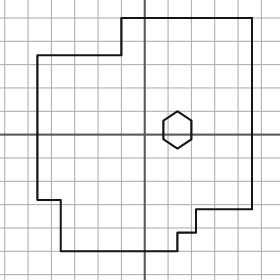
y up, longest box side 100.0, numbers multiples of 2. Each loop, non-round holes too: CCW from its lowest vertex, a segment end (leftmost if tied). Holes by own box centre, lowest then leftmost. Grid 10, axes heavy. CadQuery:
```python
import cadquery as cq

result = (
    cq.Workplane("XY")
    .moveTo(-36.0, -50.0)
    .lineTo(14.0, -50.0)
    .lineTo(14.0, -42.0)
    .lineTo(22.0, -42.0)
    .lineTo(22.0, -32.0)
    .lineTo(46.0, -32.0)
    .lineTo(46.0, 50.0)
    .lineTo(-10.0, 50.0)
    .lineTo(-10.0, 34.0)
    .lineTo(-46.0, 34.0)
    .lineTo(-46.0, -28.0)
    .lineTo(-36.0, -28.0)
    .close()
    .moveTo(14.0, -6.0)
    .lineTo(20.0, -2.0)
    .lineTo(20.0, 6.0)
    .lineTo(14.0, 10.0)
    .lineTo(8.0, 6.0)
    .lineTo(8.0, -2.0)
    .close()
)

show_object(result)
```